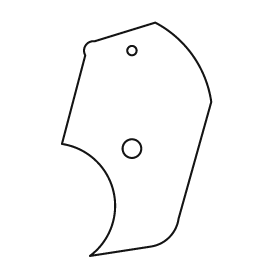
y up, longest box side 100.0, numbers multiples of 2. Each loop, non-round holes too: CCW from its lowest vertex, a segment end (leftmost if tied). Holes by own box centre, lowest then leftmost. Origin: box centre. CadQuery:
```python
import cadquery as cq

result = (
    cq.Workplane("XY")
    .moveTo(-20.0, -50.0)
    .lineTo(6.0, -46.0)
    .threePointArc((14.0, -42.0), (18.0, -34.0))
    .lineTo(32.0, 16.0)
    .threePointArc((24.0, 36.0), (8.0, 50.0))
    .lineTo(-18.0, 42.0)
    .threePointArc((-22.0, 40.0), (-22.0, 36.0))
    .lineTo(-32.0, -2.0)
    .threePointArc((-10.0, -22.0), (-20.0, -50.0))
    .close()
    .moveTo(-2.0, -4.0)
    .circle(4.0)
    .moveTo(-2.0, 38.0)
    .circle(2.0)
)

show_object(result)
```